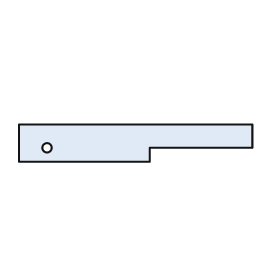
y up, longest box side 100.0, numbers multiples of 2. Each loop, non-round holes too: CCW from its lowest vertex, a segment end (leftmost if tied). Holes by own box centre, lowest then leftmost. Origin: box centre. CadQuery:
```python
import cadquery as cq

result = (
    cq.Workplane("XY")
    .moveTo(-50.0, -8.0)
    .lineTo(6.0, -8.0)
    .lineTo(6.0, -2.0)
    .lineTo(50.0, -2.0)
    .lineTo(50.0, 8.0)
    .lineTo(-50.0, 8.0)
    .close()
    .moveTo(-38.0, -2.0)
    .circle(2.0)
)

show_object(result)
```